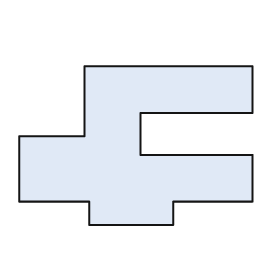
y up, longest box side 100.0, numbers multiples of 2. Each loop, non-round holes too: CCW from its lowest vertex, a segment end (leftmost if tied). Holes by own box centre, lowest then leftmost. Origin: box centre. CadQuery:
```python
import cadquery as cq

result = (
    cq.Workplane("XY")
    .moveTo(-20.0, -34.0)
    .lineTo(16.0, -34.0)
    .lineTo(16.0, -24.0)
    .lineTo(50.0, -24.0)
    .lineTo(50.0, -4.0)
    .lineTo(2.0, -4.0)
    .lineTo(2.0, 14.0)
    .lineTo(50.0, 14.0)
    .lineTo(50.0, 34.0)
    .lineTo(-22.0, 34.0)
    .lineTo(-22.0, 4.0)
    .lineTo(-50.0, 4.0)
    .lineTo(-50.0, -24.0)
    .lineTo(-20.0, -24.0)
    .close()
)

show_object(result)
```